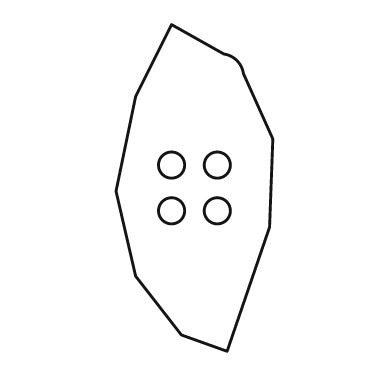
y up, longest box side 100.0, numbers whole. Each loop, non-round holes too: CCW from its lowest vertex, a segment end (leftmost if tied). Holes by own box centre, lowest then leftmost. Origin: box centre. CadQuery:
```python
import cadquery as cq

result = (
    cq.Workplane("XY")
    .moveTo(10.0, -50.0)
    .lineTo(23.0, -12.0)
    .lineTo(24.0, 15.0)
    .lineTo(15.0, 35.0)
    .threePointArc((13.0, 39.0), (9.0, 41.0))
    .lineTo(-7.0, 50.0)
    .lineTo(-18.0, 28.0)
    .lineTo(-24.0, -1.0)
    .lineTo(-18.0, -27.0)
    .lineTo(-4.0, -45.0)
    .close()
    .moveTo(-7.0, -7.0)
    .circle(4.0)
    .moveTo(7.0, -7.0)
    .circle(4.0)
    .moveTo(-7.0, 7.0)
    .circle(4.0)
    .moveTo(7.0, 7.0)
    .circle(4.0)
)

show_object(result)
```